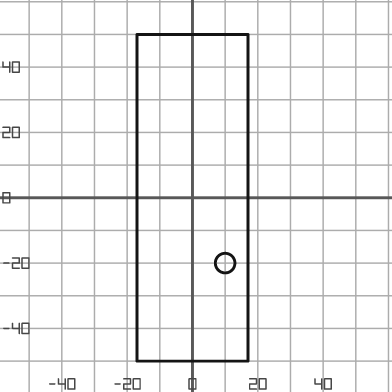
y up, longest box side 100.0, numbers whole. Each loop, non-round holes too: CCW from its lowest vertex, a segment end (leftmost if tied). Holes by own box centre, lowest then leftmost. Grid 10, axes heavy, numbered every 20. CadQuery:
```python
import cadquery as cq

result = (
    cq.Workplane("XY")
    .moveTo(-17.0, -50.0)
    .lineTo(17.0, -50.0)
    .lineTo(17.0, 50.0)
    .lineTo(-17.0, 50.0)
    .close()
    .moveTo(10.0, -20.0)
    .circle(3.0)
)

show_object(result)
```